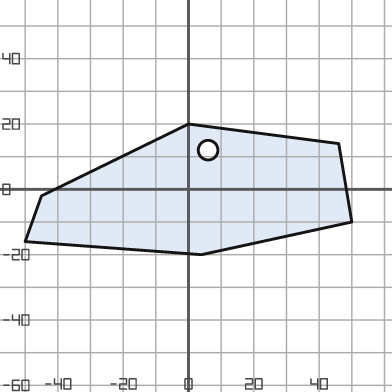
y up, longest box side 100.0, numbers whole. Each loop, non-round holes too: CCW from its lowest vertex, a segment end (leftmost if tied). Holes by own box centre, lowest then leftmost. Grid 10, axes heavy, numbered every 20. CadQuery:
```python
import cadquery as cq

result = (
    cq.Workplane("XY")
    .moveTo(4.0, -20.0)
    .lineTo(50.0, -10.0)
    .lineTo(46.0, 14.0)
    .lineTo(0.0, 20.0)
    .lineTo(-45.0, -2.0)
    .lineTo(-50.0, -16.0)
    .close()
    .moveTo(6.0, 12.0)
    .circle(3.0)
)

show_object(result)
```